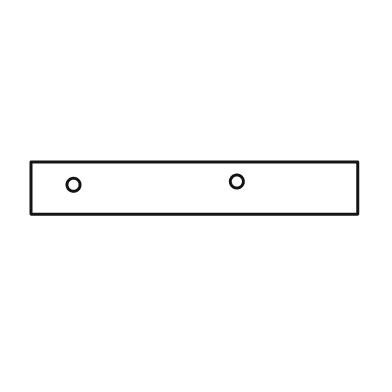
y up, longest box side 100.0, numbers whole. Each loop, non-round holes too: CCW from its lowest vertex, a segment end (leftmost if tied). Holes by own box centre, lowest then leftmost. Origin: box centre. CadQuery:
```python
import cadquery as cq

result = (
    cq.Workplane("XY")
    .moveTo(-50.0, -8.0)
    .lineTo(50.0, -8.0)
    .lineTo(50.0, 8.0)
    .lineTo(-50.0, 8.0)
    .close()
    .moveTo(-37.0, 1.0)
    .circle(2.0)
    .moveTo(13.0, 2.0)
    .circle(2.0)
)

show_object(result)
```